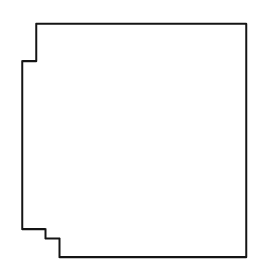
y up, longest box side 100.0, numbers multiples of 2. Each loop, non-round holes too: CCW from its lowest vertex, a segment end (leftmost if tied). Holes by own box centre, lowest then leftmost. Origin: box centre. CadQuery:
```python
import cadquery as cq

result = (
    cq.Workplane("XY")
    .moveTo(-32.0, -50.0)
    .lineTo(48.0, -50.0)
    .lineTo(48.0, 50.0)
    .lineTo(-42.0, 50.0)
    .lineTo(-42.0, 34.0)
    .lineTo(-48.0, 34.0)
    .lineTo(-48.0, -38.0)
    .lineTo(-38.0, -38.0)
    .lineTo(-38.0, -42.0)
    .lineTo(-32.0, -42.0)
    .close()
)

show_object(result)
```